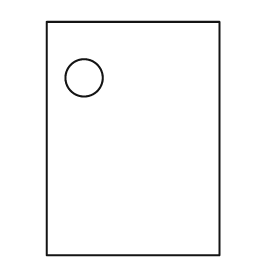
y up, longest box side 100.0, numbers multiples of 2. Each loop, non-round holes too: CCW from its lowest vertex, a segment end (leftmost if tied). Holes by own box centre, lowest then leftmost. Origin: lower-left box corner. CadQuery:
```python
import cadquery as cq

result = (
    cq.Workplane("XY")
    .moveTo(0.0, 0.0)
    .lineTo(74.0, 0.0)
    .lineTo(74.0, 100.0)
    .lineTo(0.0, 100.0)
    .close()
    .moveTo(16.0, 76.0)
    .circle(8.0)
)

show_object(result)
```